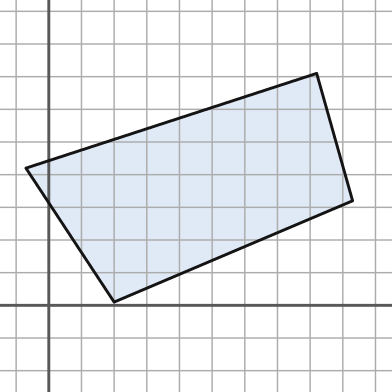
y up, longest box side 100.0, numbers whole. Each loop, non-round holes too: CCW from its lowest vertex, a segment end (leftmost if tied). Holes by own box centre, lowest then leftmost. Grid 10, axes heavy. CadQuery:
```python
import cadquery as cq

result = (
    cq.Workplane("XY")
    .moveTo(20.0, 1.0)
    .lineTo(93.0, 32.0)
    .lineTo(82.0, 71.0)
    .lineTo(-7.0, 42.0)
    .close()
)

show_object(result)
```